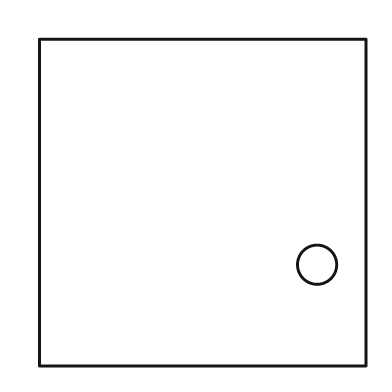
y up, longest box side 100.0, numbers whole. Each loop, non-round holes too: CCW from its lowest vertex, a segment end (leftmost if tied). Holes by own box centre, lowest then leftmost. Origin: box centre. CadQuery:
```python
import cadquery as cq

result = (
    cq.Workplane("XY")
    .moveTo(-50.0, -50.0)
    .lineTo(50.0, -50.0)
    .lineTo(50.0, 50.0)
    .lineTo(-50.0, 50.0)
    .close()
    .moveTo(35.0, -19.0)
    .circle(6.0)
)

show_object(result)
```